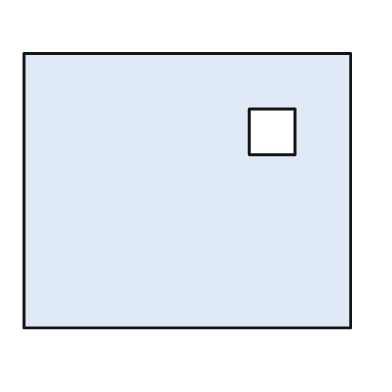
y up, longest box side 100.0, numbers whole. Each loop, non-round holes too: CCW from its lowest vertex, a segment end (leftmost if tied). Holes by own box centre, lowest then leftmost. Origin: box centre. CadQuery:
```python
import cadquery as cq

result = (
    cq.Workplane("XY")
    .moveTo(-50.0, -42.0)
    .lineTo(50.0, -42.0)
    .lineTo(50.0, 42.0)
    .lineTo(-50.0, 42.0)
    .close()
    .moveTo(19.0, 11.0)
    .lineTo(33.0, 11.0)
    .lineTo(33.0, 25.0)
    .lineTo(19.0, 25.0)
    .close()
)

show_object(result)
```